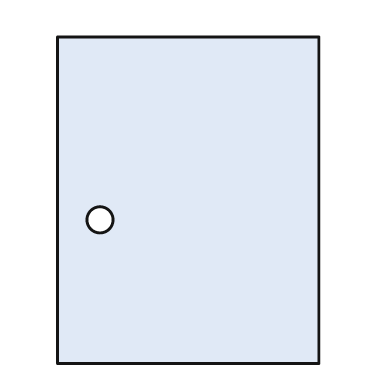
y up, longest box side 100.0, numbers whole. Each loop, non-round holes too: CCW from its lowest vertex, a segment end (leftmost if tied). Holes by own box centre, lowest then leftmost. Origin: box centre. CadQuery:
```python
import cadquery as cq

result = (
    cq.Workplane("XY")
    .moveTo(-40.0, -50.0)
    .lineTo(40.0, -50.0)
    .lineTo(40.0, 50.0)
    .lineTo(-40.0, 50.0)
    .close()
    .moveTo(-27.0, -6.0)
    .circle(4.0)
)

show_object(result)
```